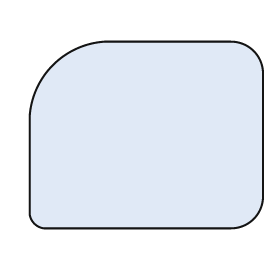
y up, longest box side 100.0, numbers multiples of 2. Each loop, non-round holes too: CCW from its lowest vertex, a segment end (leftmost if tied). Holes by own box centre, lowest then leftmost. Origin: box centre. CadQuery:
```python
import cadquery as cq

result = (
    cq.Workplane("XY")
    .moveTo(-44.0, -40.0)
    .lineTo(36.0, -40.0)
    .threePointArc((46.0, -36.0), (50.0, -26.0))
    .lineTo(50.0, 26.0)
    .threePointArc((46.0, 36.0), (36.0, 40.0))
    .lineTo(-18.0, 40.0)
    .threePointArc((-40.0, 30.0), (-50.0, 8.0))
    .lineTo(-50.0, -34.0)
    .threePointArc((-48.0, -38.0), (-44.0, -40.0))
    .close()
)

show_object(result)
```